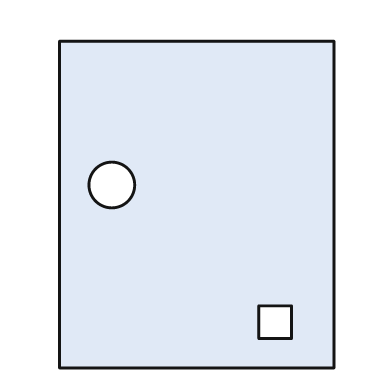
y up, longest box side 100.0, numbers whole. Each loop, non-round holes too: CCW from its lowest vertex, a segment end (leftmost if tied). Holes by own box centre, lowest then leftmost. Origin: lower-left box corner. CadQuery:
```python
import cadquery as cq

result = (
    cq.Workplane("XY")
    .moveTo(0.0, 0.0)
    .lineTo(84.0, 0.0)
    .lineTo(84.0, 100.0)
    .lineTo(0.0, 100.0)
    .close()
    .moveTo(61.0, 9.0)
    .lineTo(71.0, 9.0)
    .lineTo(71.0, 19.0)
    .lineTo(61.0, 19.0)
    .close()
    .moveTo(16.0, 56.0)
    .circle(7.0)
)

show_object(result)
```